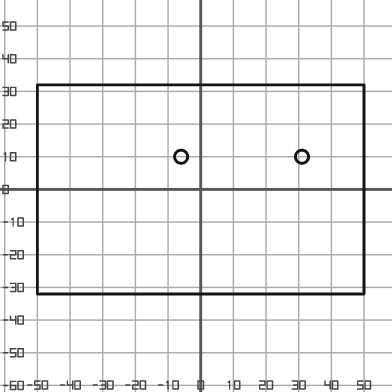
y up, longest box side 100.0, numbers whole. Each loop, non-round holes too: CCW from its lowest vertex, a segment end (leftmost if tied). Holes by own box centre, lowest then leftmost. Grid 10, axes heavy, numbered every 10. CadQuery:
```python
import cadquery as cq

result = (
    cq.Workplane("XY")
    .moveTo(-50.0, -32.0)
    .lineTo(50.0, -32.0)
    .lineTo(50.0, 32.0)
    .lineTo(-50.0, 32.0)
    .close()
    .moveTo(-6.0, 10.0)
    .circle(2.0)
    .moveTo(31.0, 10.0)
    .circle(2.0)
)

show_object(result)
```